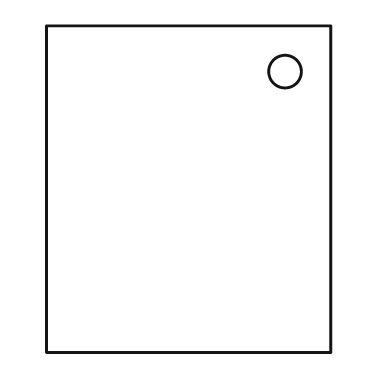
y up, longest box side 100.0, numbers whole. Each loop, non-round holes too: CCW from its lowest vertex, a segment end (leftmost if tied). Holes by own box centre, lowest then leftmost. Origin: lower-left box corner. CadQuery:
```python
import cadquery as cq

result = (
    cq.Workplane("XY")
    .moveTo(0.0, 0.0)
    .lineTo(87.0, 0.0)
    .lineTo(87.0, 100.0)
    .lineTo(0.0, 100.0)
    .close()
    .moveTo(73.0, 86.0)
    .circle(5.0)
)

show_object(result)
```